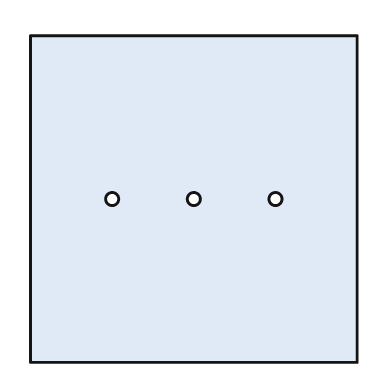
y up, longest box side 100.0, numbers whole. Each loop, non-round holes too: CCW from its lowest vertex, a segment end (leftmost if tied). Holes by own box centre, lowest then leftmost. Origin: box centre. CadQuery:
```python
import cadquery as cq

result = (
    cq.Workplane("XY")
    .moveTo(-50.0, -50.0)
    .lineTo(50.0, -50.0)
    .lineTo(50.0, 50.0)
    .lineTo(-50.0, 50.0)
    .close()
    .moveTo(-25.0, 0.0)
    .circle(2.0)
    .moveTo(0.0, 0.0)
    .circle(2.0)
    .moveTo(25.0, 0.0)
    .circle(2.0)
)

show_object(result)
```